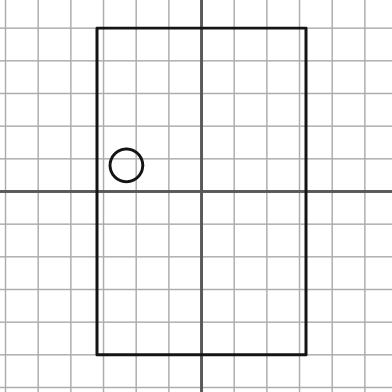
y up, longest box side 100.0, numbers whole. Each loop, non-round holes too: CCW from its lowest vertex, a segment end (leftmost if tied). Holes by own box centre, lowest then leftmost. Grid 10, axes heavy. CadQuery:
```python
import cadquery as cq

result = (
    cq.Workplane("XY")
    .moveTo(-32.0, -50.0)
    .lineTo(32.0, -50.0)
    .lineTo(32.0, 50.0)
    .lineTo(-32.0, 50.0)
    .close()
    .moveTo(-23.0, 8.0)
    .circle(5.0)
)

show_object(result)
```